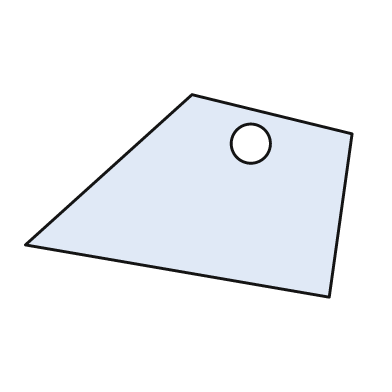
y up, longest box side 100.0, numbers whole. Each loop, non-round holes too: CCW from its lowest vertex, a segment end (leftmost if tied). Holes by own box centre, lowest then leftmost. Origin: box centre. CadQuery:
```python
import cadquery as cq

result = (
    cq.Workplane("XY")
    .moveTo(43.0, -31.0)
    .lineTo(50.0, 19.0)
    .lineTo(1.0, 31.0)
    .lineTo(-50.0, -15.0)
    .close()
    .moveTo(19.0, 16.0)
    .circle(6.0)
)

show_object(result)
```